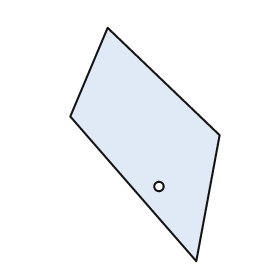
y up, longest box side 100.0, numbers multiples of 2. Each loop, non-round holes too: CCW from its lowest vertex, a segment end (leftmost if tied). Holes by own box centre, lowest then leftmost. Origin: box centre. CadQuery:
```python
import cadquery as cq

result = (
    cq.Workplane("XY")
    .moveTo(22.0, -50.0)
    .lineTo(32.0, 4.0)
    .lineTo(-16.0, 50.0)
    .lineTo(-32.0, 12.0)
    .close()
    .moveTo(6.0, -18.0)
    .circle(2.0)
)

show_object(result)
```